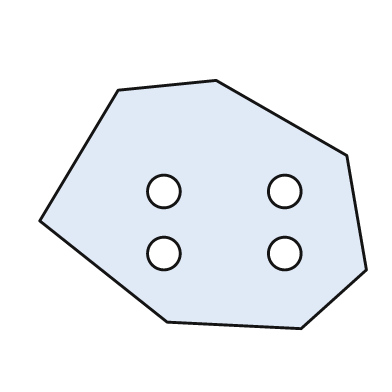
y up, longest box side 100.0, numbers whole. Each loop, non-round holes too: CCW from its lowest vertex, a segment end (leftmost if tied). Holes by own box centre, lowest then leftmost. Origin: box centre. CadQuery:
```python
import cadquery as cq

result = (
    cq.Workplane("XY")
    .moveTo(30.0, -38.0)
    .lineTo(50.0, -20.0)
    .lineTo(44.0, 15.0)
    .lineTo(4.0, 38.0)
    .lineTo(-26.0, 35.0)
    .lineTo(-50.0, -5.0)
    .lineTo(-11.0, -36.0)
    .close()
    .moveTo(-12.0, -15.0)
    .circle(5.0)
    .moveTo(25.0, -15.0)
    .circle(5.0)
    .moveTo(-12.0, 4.0)
    .circle(5.0)
    .moveTo(25.0, 4.0)
    .circle(5.0)
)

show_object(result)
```